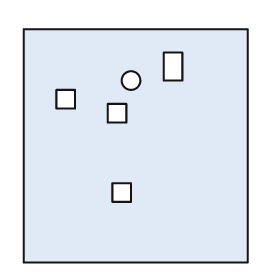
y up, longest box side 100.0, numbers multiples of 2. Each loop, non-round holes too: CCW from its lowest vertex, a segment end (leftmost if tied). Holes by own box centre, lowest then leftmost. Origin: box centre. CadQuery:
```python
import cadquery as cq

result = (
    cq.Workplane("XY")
    .moveTo(-48.0, -50.0)
    .lineTo(48.0, -50.0)
    .lineTo(48.0, 50.0)
    .lineTo(-48.0, 50.0)
    .close()
    .moveTo(-10.0, -24.0)
    .lineTo(-2.0, -24.0)
    .lineTo(-2.0, -16.0)
    .lineTo(-10.0, -16.0)
    .close()
    .moveTo(-12.0, 10.0)
    .lineTo(-4.0, 10.0)
    .lineTo(-4.0, 18.0)
    .lineTo(-12.0, 18.0)
    .close()
    .moveTo(-34.0, 16.0)
    .lineTo(-26.0, 16.0)
    .lineTo(-26.0, 24.0)
    .lineTo(-34.0, 24.0)
    .close()
    .moveTo(-2.0, 28.0)
    .circle(4.0)
    .moveTo(12.0, 28.0)
    .lineTo(20.0, 28.0)
    .lineTo(20.0, 40.0)
    .lineTo(12.0, 40.0)
    .close()
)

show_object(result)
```